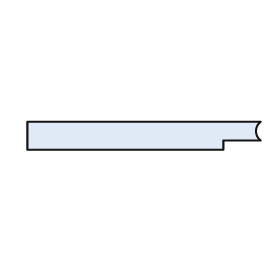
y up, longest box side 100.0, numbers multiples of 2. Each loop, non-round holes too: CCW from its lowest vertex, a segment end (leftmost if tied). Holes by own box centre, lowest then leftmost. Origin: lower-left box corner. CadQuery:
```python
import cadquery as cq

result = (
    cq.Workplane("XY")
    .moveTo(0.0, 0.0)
    .lineTo(84.0, 0.0)
    .lineTo(84.0, 4.0)
    .lineTo(100.0, 4.0)
    .threePointArc((98.0, 8.0), (100.0, 12.0))
    .lineTo(0.0, 12.0)
    .close()
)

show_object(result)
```